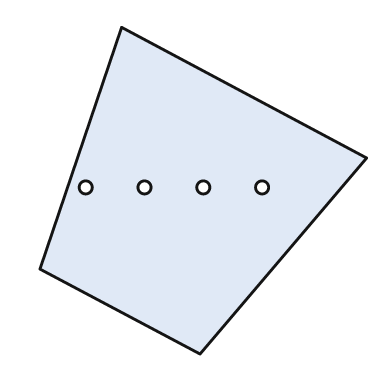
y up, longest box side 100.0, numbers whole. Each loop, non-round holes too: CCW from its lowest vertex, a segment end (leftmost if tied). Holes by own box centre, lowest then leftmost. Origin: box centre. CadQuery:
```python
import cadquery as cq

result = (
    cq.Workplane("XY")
    .moveTo(-1.0, -50.0)
    .lineTo(50.0, 10.0)
    .lineTo(-25.0, 50.0)
    .lineTo(-50.0, -24.0)
    .close()
    .moveTo(-36.0, 1.0)
    .circle(2.0)
    .moveTo(-18.0, 1.0)
    .circle(2.0)
    .moveTo(0.0, 1.0)
    .circle(2.0)
    .moveTo(18.0, 1.0)
    .circle(2.0)
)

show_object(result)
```